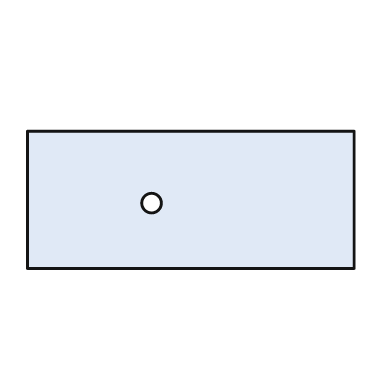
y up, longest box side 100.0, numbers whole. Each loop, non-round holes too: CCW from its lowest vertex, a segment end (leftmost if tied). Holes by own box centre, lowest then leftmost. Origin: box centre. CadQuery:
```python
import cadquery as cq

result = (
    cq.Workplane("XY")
    .moveTo(-50.0, -21.0)
    .lineTo(50.0, -21.0)
    .lineTo(50.0, 21.0)
    .lineTo(-50.0, 21.0)
    .close()
    .moveTo(-12.0, -1.0)
    .circle(3.0)
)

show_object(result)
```